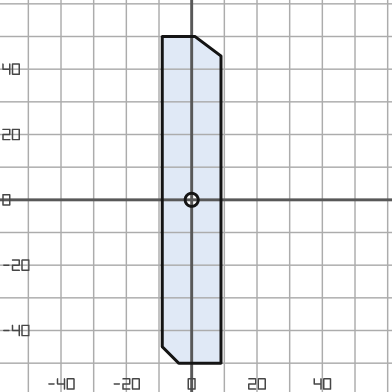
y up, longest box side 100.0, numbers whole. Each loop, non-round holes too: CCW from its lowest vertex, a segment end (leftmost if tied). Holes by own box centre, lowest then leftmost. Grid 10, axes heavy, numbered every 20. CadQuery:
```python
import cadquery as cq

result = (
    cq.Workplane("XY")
    .moveTo(-4.0, -50.0)
    .lineTo(9.0, -50.0)
    .lineTo(9.0, 44.0)
    .lineTo(1.0, 50.0)
    .lineTo(-9.0, 50.0)
    .lineTo(-9.0, -45.0)
    .close()
    .moveTo(0.0, 0.0)
    .circle(2.0)
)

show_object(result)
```